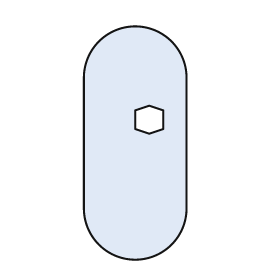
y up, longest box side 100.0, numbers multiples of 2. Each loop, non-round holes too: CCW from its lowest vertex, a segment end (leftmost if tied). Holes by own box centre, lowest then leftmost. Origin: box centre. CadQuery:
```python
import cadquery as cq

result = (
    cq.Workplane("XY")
    .moveTo(-22.0, -28.0)
    .threePointArc((0.0, -50.0), (22.0, -28.0))
    .lineTo(22.0, 28.0)
    .threePointArc((0.0, 50.0), (-22.0, 28.0))
    .close()
    .moveTo(6.0, 4.0)
    .lineTo(12.0, 6.0)
    .lineTo(12.0, 14.0)
    .lineTo(6.0, 16.0)
    .lineTo(0.0, 14.0)
    .lineTo(0.0, 6.0)
    .close()
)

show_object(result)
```